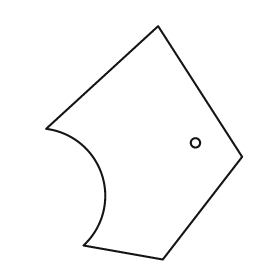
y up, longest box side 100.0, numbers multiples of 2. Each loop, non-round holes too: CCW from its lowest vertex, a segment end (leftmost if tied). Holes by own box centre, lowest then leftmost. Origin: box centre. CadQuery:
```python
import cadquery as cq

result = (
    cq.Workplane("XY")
    .moveTo(8.0, -50.0)
    .lineTo(42.0, -6.0)
    .lineTo(6.0, 50.0)
    .lineTo(-42.0, 6.0)
    .threePointArc((-18.0, -14.0), (-26.0, -44.0))
    .close()
    .moveTo(22.0, 0.0)
    .circle(2.0)
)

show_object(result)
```